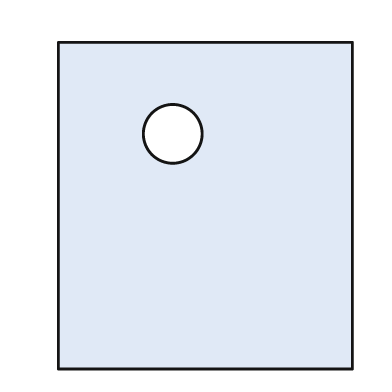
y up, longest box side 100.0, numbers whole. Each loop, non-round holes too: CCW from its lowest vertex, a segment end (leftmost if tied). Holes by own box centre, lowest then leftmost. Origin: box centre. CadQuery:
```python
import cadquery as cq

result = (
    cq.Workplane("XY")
    .moveTo(-45.0, -50.0)
    .lineTo(45.0, -50.0)
    .lineTo(45.0, 50.0)
    .lineTo(-45.0, 50.0)
    .close()
    .moveTo(-10.0, 22.0)
    .circle(9.0)
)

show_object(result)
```